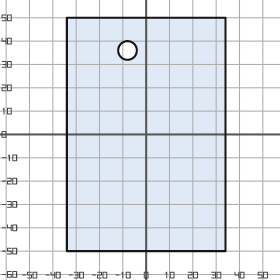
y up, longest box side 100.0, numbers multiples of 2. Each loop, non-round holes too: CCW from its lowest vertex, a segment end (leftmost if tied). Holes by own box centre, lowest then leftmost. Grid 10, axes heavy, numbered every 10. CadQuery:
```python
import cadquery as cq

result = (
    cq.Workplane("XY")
    .moveTo(-34.0, -50.0)
    .lineTo(34.0, -50.0)
    .lineTo(34.0, 50.0)
    .lineTo(-34.0, 50.0)
    .close()
    .moveTo(-8.0, 36.0)
    .circle(4.0)
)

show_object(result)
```